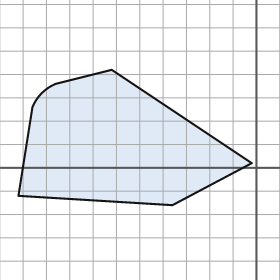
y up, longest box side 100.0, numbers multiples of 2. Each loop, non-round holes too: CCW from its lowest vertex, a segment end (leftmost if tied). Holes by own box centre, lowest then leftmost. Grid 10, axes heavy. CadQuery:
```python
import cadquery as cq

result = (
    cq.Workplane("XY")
    .moveTo(-36.0, -16.0)
    .lineTo(-2.0, 2.0)
    .lineTo(-62.0, 42.0)
    .lineTo(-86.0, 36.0)
    .threePointArc((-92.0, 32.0), (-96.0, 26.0))
    .lineTo(-102.0, -12.0)
    .close()
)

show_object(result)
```